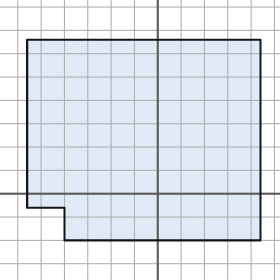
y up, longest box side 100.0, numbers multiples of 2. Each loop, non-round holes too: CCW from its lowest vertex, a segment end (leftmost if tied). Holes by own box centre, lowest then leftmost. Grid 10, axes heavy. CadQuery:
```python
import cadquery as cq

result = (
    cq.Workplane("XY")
    .moveTo(-40.0, -20.0)
    .lineTo(44.0, -20.0)
    .lineTo(44.0, 66.0)
    .lineTo(-56.0, 66.0)
    .lineTo(-56.0, -6.0)
    .lineTo(-40.0, -6.0)
    .close()
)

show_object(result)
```